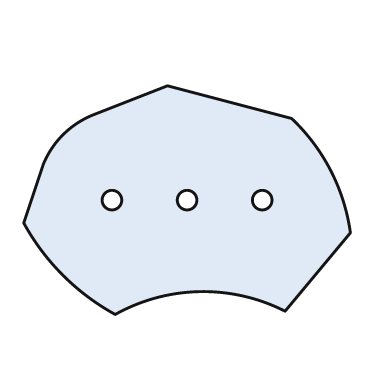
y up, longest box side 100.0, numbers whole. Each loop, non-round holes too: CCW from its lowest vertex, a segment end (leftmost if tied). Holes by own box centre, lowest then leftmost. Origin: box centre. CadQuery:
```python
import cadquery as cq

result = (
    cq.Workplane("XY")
    .moveTo(-22.0, -35.0)
    .threePointArc((4.0, -28.0), (30.0, -34.0))
    .lineTo(50.0, -10.0)
    .threePointArc((44.0, 9.0), (32.0, 25.0))
    .lineTo(-6.0, 35.0)
    .lineTo(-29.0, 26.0)
    .threePointArc((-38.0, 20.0), (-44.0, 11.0))
    .lineTo(-50.0, -7.0)
    .threePointArc((-38.0, -23.0), (-22.0, -35.0))
    .close()
    .moveTo(-23.0, 0.0)
    .circle(3.0)
    .moveTo(0.0, 0.0)
    .circle(3.0)
    .moveTo(23.0, 0.0)
    .circle(3.0)
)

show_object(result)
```